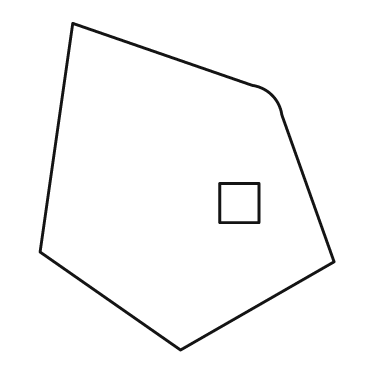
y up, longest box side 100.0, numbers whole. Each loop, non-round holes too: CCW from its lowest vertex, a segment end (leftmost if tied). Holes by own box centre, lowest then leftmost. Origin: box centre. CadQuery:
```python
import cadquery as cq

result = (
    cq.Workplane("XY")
    .moveTo(-2.0, -50.0)
    .lineTo(45.0, -23.0)
    .lineTo(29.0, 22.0)
    .threePointArc((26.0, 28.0), (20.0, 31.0))
    .lineTo(-35.0, 50.0)
    .lineTo(-45.0, -20.0)
    .close()
    .moveTo(10.0, -11.0)
    .lineTo(22.0, -11.0)
    .lineTo(22.0, 1.0)
    .lineTo(10.0, 1.0)
    .close()
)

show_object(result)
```